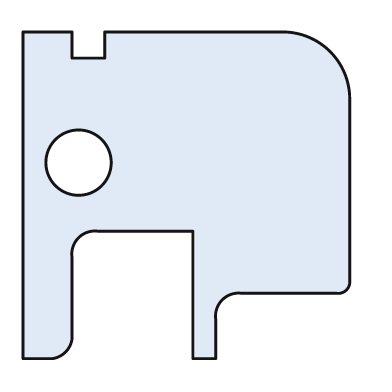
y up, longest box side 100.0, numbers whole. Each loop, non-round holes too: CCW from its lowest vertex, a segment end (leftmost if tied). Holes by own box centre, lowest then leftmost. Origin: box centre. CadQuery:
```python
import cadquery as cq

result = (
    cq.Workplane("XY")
    .moveTo(-50.0, -50.0)
    .lineTo(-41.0, -50.0)
    .threePointArc((-37.0, -48.0), (-35.0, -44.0))
    .lineTo(-35.0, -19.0)
    .threePointArc((-33.0, -13.0), (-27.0, -11.0))
    .lineTo(2.0, -11.0)
    .lineTo(2.0, -50.0)
    .lineTo(9.0, -50.0)
    .lineTo(9.0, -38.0)
    .threePointArc((11.0, -32.0), (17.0, -30.0))
    .lineTo(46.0, -30.0)
    .threePointArc((49.0, -29.0), (50.0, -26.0))
    .lineTo(50.0, 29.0)
    .threePointArc((44.0, 44.0), (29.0, 50.0))
    .lineTo(-25.0, 50.0)
    .lineTo(-25.0, 42.0)
    .lineTo(-35.0, 42.0)
    .lineTo(-35.0, 50.0)
    .lineTo(-50.0, 50.0)
    .close()
    .moveTo(-33.0, 10.0)
    .circle(10.0)
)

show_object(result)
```